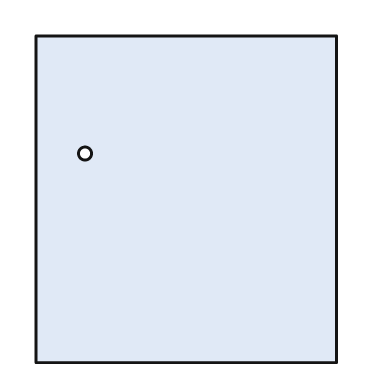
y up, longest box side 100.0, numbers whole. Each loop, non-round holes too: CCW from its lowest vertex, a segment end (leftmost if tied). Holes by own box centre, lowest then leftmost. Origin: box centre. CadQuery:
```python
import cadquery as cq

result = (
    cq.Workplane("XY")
    .moveTo(-46.0, -50.0)
    .lineTo(46.0, -50.0)
    .lineTo(46.0, 50.0)
    .lineTo(-46.0, 50.0)
    .close()
    .moveTo(-31.0, 14.0)
    .circle(2.0)
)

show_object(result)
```